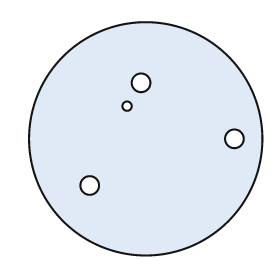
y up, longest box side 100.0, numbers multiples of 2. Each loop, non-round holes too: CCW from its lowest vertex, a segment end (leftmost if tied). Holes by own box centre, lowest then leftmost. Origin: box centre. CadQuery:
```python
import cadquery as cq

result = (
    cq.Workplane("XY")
    .moveTo(0.0, 0.0)
    .circle(50.0)
    .moveTo(-24.0, -20.0)
    .circle(4.0)
    .moveTo(38.0, 0.0)
    .circle(4.0)
    .moveTo(-8.0, 14.0)
    .circle(2.0)
    .moveTo(-2.0, 24.0)
    .circle(4.0)
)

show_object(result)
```